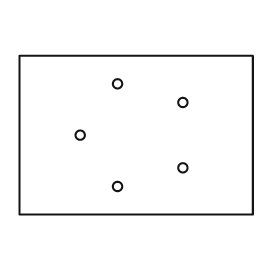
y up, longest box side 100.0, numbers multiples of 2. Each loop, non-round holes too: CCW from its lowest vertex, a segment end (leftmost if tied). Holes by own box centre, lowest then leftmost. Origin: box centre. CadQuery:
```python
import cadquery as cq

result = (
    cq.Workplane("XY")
    .moveTo(-50.0, -34.0)
    .lineTo(50.0, -34.0)
    .lineTo(50.0, 34.0)
    .lineTo(-50.0, 34.0)
    .close()
    .moveTo(-8.0, -22.0)
    .circle(2.0)
    .moveTo(20.0, -14.0)
    .circle(2.0)
    .moveTo(-24.0, 0.0)
    .circle(2.0)
    .moveTo(20.0, 14.0)
    .circle(2.0)
    .moveTo(-8.0, 22.0)
    .circle(2.0)
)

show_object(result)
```